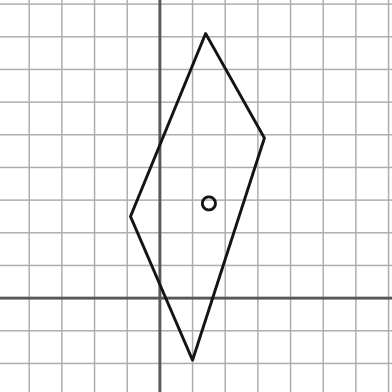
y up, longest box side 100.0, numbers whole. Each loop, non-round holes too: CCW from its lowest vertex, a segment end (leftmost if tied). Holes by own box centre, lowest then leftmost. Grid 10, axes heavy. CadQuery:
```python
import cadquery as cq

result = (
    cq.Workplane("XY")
    .moveTo(10.0, -19.0)
    .lineTo(32.0, 49.0)
    .lineTo(14.0, 81.0)
    .lineTo(-9.0, 25.0)
    .close()
    .moveTo(15.0, 29.0)
    .circle(2.0)
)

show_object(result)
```